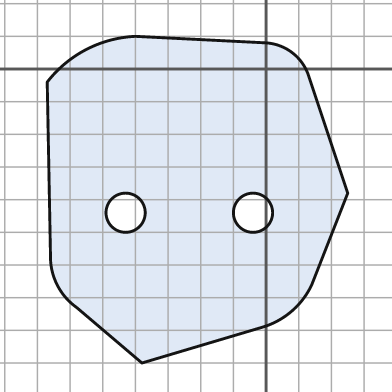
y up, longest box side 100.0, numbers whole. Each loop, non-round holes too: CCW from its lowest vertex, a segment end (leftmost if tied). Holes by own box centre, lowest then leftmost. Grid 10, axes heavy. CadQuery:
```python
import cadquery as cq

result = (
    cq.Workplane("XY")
    .moveTo(-38.0, -90.0)
    .lineTo(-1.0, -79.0)
    .threePointArc((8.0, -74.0), (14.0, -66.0))
    .lineTo(25.0, -38.0)
    .lineTo(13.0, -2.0)
    .threePointArc((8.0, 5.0), (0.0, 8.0))
    .lineTo(-40.0, 10.0)
    .threePointArc((-55.0, 6.0), (-67.0, -4.0))
    .lineTo(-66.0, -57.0)
    .threePointArc((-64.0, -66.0), (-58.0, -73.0))
    .close()
    .moveTo(-43.0, -44.0)
    .circle(6.0)
    .moveTo(-4.0, -44.0)
    .circle(6.0)
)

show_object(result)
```